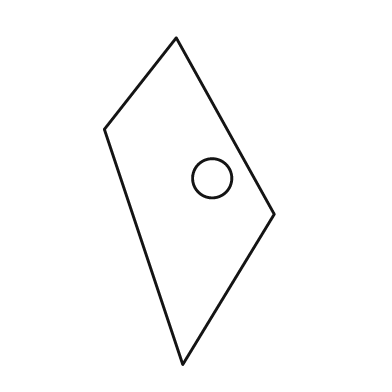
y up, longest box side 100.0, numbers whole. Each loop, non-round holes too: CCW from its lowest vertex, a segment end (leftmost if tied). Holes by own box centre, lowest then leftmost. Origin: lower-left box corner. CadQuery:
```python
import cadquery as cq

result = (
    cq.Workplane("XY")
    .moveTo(24.0, 0.0)
    .lineTo(52.0, 46.0)
    .lineTo(22.0, 100.0)
    .lineTo(0.0, 72.0)
    .close()
    .moveTo(33.0, 57.0)
    .circle(6.0)
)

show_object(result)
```